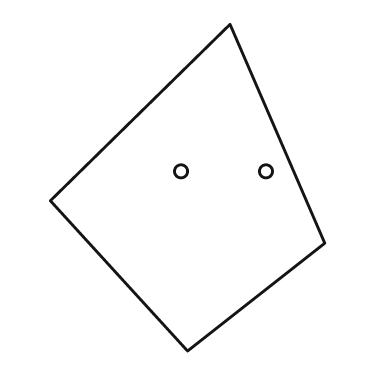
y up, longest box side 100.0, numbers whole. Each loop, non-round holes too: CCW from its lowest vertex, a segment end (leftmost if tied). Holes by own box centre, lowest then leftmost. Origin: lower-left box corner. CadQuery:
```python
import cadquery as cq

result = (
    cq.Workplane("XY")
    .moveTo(42.0, 0.0)
    .lineTo(84.0, 33.0)
    .lineTo(55.0, 100.0)
    .lineTo(0.0, 46.0)
    .close()
    .moveTo(40.0, 55.0)
    .circle(2.0)
    .moveTo(66.0, 55.0)
    .circle(2.0)
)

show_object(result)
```